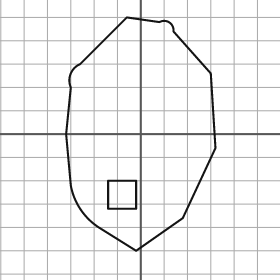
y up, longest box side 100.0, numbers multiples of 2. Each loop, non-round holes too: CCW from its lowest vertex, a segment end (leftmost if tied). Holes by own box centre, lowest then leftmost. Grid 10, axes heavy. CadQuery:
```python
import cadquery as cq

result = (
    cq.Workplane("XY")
    .moveTo(-2.0, -50.0)
    .lineTo(18.0, -36.0)
    .lineTo(32.0, -6.0)
    .lineTo(30.0, 26.0)
    .lineTo(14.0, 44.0)
    .threePointArc((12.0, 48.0), (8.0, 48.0))
    .lineTo(-6.0, 50.0)
    .lineTo(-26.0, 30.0)
    .threePointArc((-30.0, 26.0), (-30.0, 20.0))
    .lineTo(-32.0, 0.0)
    .lineTo(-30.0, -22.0)
    .threePointArc((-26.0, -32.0), (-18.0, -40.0))
    .close()
    .moveTo(-14.0, -32.0)
    .lineTo(-2.0, -32.0)
    .lineTo(-2.0, -20.0)
    .lineTo(-14.0, -20.0)
    .close()
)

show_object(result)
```